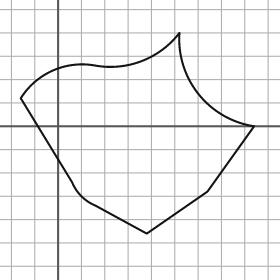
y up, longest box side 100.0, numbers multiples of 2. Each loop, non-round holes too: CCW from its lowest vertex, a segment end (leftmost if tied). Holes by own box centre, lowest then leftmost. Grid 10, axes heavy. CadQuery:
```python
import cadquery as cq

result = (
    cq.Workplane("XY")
    .moveTo(38.0, -46.0)
    .lineTo(64.0, -28.0)
    .lineTo(84.0, 0.0)
    .threePointArc((60.0, 14.0), (52.0, 40.0))
    .threePointArc((36.0, 28.0), (16.0, 26.0))
    .threePointArc((-2.0, 24.0), (-16.0, 12.0))
    .lineTo(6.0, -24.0)
    .threePointArc((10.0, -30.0), (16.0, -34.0))
    .close()
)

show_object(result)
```